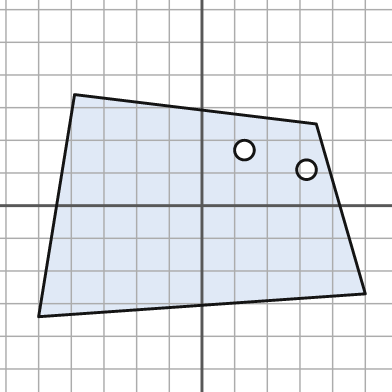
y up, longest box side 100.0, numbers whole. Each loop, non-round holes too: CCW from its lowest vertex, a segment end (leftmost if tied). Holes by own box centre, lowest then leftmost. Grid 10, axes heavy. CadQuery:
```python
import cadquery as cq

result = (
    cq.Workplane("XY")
    .moveTo(-50.0, -34.0)
    .lineTo(50.0, -27.0)
    .lineTo(35.0, 25.0)
    .lineTo(-39.0, 34.0)
    .close()
    .moveTo(32.0, 11.0)
    .circle(3.0)
    .moveTo(13.0, 17.0)
    .circle(3.0)
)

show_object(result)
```